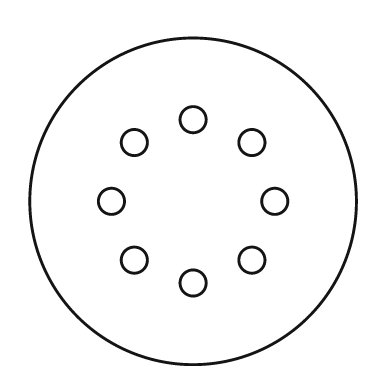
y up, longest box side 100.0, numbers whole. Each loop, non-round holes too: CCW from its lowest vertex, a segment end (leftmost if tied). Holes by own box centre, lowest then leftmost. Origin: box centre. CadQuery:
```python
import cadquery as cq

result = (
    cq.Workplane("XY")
    .moveTo(0.0, 0.0)
    .circle(50.0)
    .moveTo(0.0, -25.0)
    .circle(4.0)
    .moveTo(-18.0, -18.0)
    .circle(4.0)
    .moveTo(18.0, -18.0)
    .circle(4.0)
    .moveTo(-25.0, 0.0)
    .circle(4.0)
    .moveTo(25.0, 0.0)
    .circle(4.0)
    .moveTo(-18.0, 18.0)
    .circle(4.0)
    .moveTo(18.0, 18.0)
    .circle(4.0)
    .moveTo(0.0, 25.0)
    .circle(4.0)
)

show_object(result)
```